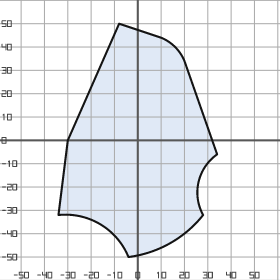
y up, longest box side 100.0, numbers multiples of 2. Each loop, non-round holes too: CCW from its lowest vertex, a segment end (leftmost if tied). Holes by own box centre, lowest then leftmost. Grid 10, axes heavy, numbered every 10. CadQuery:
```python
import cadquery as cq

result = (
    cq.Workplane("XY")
    .moveTo(-4.0, -50.0)
    .threePointArc((14.0, -44.0), (28.0, -32.0))
    .threePointArc((26.0, -18.0), (34.0, -6.0))
    .lineTo(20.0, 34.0)
    .threePointArc((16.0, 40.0), (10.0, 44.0))
    .lineTo(-8.0, 50.0)
    .lineTo(-30.0, 0.0)
    .lineTo(-34.0, -32.0)
    .threePointArc((-16.0, -36.0), (-4.0, -50.0))
    .close()
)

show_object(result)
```